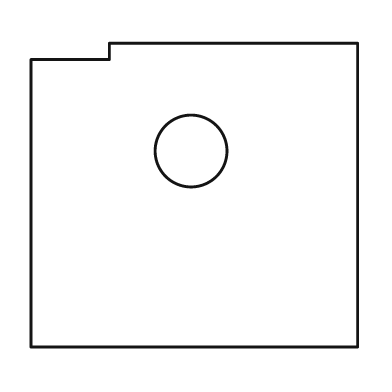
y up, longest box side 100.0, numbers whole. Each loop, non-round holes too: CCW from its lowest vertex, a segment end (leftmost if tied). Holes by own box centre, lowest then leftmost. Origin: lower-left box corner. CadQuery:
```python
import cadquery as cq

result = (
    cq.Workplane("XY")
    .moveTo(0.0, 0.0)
    .lineTo(100.0, 0.0)
    .lineTo(100.0, 93.0)
    .lineTo(24.0, 93.0)
    .lineTo(24.0, 88.0)
    .lineTo(0.0, 88.0)
    .close()
    .moveTo(49.0, 60.0)
    .circle(11.0)
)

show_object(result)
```